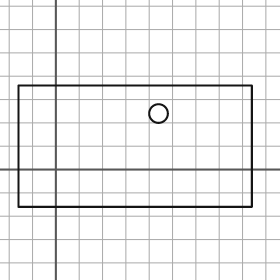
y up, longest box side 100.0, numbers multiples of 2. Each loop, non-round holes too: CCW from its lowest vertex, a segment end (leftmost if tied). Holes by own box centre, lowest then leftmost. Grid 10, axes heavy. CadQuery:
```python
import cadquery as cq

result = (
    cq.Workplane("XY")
    .moveTo(-16.0, -16.0)
    .lineTo(84.0, -16.0)
    .lineTo(84.0, 36.0)
    .lineTo(-16.0, 36.0)
    .close()
    .moveTo(44.0, 24.0)
    .circle(4.0)
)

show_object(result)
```